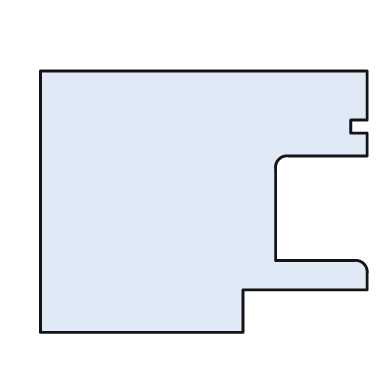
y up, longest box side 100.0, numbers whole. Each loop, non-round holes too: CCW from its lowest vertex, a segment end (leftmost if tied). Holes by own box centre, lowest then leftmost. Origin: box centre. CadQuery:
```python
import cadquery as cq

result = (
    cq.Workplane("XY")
    .moveTo(-50.0, -40.0)
    .lineTo(12.0, -40.0)
    .lineTo(12.0, -27.0)
    .lineTo(50.0, -27.0)
    .lineTo(50.0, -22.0)
    .threePointArc((49.0, -19.0), (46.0, -18.0))
    .lineTo(22.0, -18.0)
    .lineTo(22.0, 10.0)
    .threePointArc((23.0, 13.0), (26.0, 14.0))
    .lineTo(50.0, 14.0)
    .lineTo(50.0, 21.0)
    .lineTo(45.0, 21.0)
    .lineTo(45.0, 25.0)
    .lineTo(50.0, 25.0)
    .lineTo(50.0, 40.0)
    .lineTo(-50.0, 40.0)
    .close()
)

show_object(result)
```